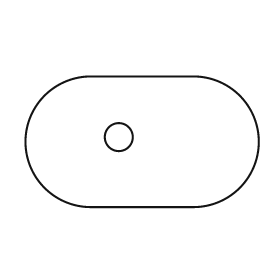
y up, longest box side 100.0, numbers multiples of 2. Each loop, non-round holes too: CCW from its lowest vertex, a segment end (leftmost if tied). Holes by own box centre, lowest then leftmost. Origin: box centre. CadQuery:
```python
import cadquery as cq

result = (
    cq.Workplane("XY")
    .moveTo(-22.0, -28.0)
    .lineTo(22.0, -28.0)
    .threePointArc((50.0, 0.0), (22.0, 28.0))
    .lineTo(-22.0, 28.0)
    .threePointArc((-50.0, 0.0), (-22.0, -28.0))
    .close()
    .moveTo(-10.0, 2.0)
    .circle(6.0)
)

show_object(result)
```